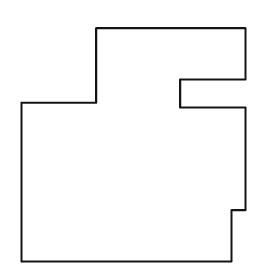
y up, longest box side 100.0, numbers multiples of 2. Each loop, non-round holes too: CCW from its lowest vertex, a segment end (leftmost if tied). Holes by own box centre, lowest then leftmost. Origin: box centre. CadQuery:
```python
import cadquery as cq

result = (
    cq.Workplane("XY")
    .moveTo(-48.0, -50.0)
    .lineTo(42.0, -50.0)
    .lineTo(42.0, -28.0)
    .lineTo(48.0, -28.0)
    .lineTo(48.0, 16.0)
    .lineTo(20.0, 16.0)
    .lineTo(20.0, 28.0)
    .lineTo(48.0, 28.0)
    .lineTo(48.0, 50.0)
    .lineTo(-16.0, 50.0)
    .lineTo(-16.0, 18.0)
    .lineTo(-48.0, 18.0)
    .close()
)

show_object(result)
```